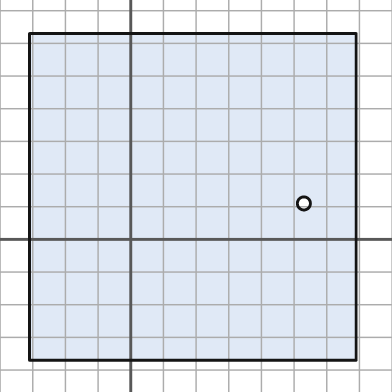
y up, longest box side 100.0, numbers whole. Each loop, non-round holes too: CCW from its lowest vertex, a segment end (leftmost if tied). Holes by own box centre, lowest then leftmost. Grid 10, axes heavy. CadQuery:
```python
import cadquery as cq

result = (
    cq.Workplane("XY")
    .moveTo(-31.0, -37.0)
    .lineTo(69.0, -37.0)
    .lineTo(69.0, 63.0)
    .lineTo(-31.0, 63.0)
    .close()
    .moveTo(53.0, 11.0)
    .circle(2.0)
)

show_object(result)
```